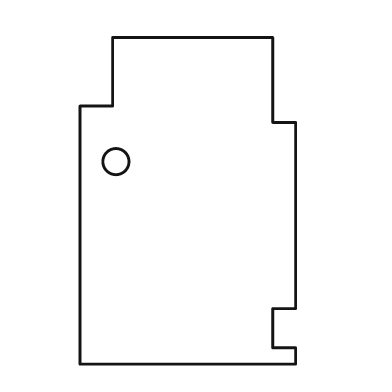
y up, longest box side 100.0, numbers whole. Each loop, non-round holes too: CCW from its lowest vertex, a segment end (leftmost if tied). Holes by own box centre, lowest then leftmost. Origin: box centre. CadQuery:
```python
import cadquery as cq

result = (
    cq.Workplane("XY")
    .moveTo(-33.0, -50.0)
    .lineTo(33.0, -50.0)
    .lineTo(33.0, -45.0)
    .lineTo(26.0, -45.0)
    .lineTo(26.0, -33.0)
    .lineTo(33.0, -33.0)
    .lineTo(33.0, 24.0)
    .lineTo(26.0, 24.0)
    .lineTo(26.0, 50.0)
    .lineTo(-23.0, 50.0)
    .lineTo(-23.0, 29.0)
    .lineTo(-33.0, 29.0)
    .close()
    .moveTo(-22.0, 12.0)
    .circle(4.0)
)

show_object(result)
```